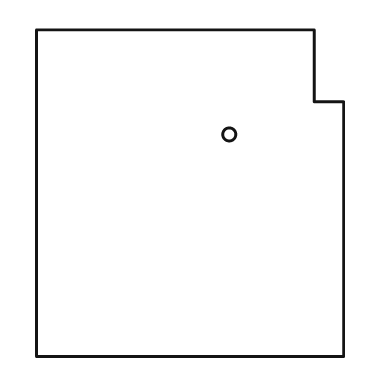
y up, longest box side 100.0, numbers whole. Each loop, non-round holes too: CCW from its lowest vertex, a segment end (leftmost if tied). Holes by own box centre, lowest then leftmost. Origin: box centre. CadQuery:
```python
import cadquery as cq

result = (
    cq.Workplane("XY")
    .moveTo(-47.0, -50.0)
    .lineTo(47.0, -50.0)
    .lineTo(47.0, 28.0)
    .lineTo(38.0, 28.0)
    .lineTo(38.0, 50.0)
    .lineTo(-47.0, 50.0)
    .close()
    .moveTo(12.0, 18.0)
    .circle(2.0)
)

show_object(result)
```